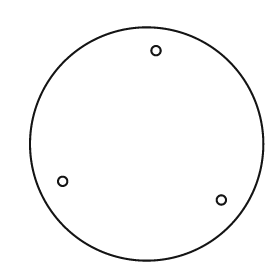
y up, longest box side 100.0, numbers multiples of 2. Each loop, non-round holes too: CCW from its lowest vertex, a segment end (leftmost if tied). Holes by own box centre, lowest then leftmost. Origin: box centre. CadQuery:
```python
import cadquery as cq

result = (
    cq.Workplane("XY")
    .moveTo(0.0, 0.0)
    .circle(50.0)
    .moveTo(32.0, -24.0)
    .circle(2.0)
    .moveTo(-36.0, -16.0)
    .circle(2.0)
    .moveTo(4.0, 40.0)
    .circle(2.0)
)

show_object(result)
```